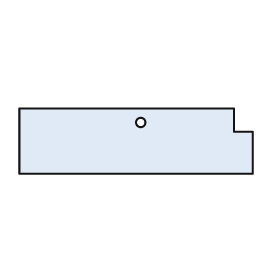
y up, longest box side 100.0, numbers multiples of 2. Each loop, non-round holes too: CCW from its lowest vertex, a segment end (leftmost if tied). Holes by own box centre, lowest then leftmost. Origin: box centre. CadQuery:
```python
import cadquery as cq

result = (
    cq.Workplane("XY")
    .moveTo(-50.0, -14.0)
    .lineTo(50.0, -14.0)
    .lineTo(50.0, 4.0)
    .lineTo(42.0, 4.0)
    .lineTo(42.0, 14.0)
    .lineTo(-50.0, 14.0)
    .close()
    .moveTo(2.0, 8.0)
    .circle(2.0)
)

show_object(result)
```